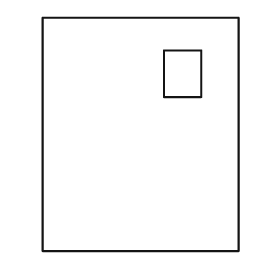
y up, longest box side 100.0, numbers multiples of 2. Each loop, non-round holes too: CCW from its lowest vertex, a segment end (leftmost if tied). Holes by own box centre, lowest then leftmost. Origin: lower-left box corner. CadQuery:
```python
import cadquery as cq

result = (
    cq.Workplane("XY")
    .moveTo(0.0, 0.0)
    .lineTo(84.0, 0.0)
    .lineTo(84.0, 100.0)
    .lineTo(0.0, 100.0)
    .close()
    .moveTo(52.0, 66.0)
    .lineTo(68.0, 66.0)
    .lineTo(68.0, 86.0)
    .lineTo(52.0, 86.0)
    .close()
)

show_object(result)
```